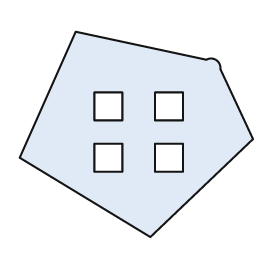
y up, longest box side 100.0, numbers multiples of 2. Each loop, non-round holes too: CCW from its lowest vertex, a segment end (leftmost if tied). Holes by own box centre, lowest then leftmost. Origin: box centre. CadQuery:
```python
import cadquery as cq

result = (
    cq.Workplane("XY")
    .moveTo(6.0, -44.0)
    .lineTo(50.0, -2.0)
    .lineTo(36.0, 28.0)
    .threePointArc((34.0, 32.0), (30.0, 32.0))
    .lineTo(-26.0, 44.0)
    .lineTo(-50.0, -10.0)
    .close()
    .moveTo(-18.0, -16.0)
    .lineTo(-6.0, -16.0)
    .lineTo(-6.0, -4.0)
    .lineTo(-18.0, -4.0)
    .close()
    .moveTo(8.0, -16.0)
    .lineTo(20.0, -16.0)
    .lineTo(20.0, -4.0)
    .lineTo(8.0, -4.0)
    .close()
    .moveTo(-18.0, 6.0)
    .lineTo(-6.0, 6.0)
    .lineTo(-6.0, 18.0)
    .lineTo(-18.0, 18.0)
    .close()
    .moveTo(8.0, 6.0)
    .lineTo(20.0, 6.0)
    .lineTo(20.0, 18.0)
    .lineTo(8.0, 18.0)
    .close()
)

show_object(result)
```